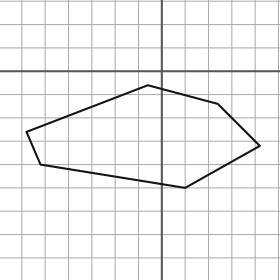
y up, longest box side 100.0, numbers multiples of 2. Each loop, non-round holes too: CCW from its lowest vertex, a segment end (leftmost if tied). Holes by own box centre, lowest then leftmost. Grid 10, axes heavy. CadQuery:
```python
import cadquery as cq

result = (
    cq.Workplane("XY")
    .moveTo(10.0, -50.0)
    .lineTo(42.0, -32.0)
    .lineTo(24.0, -14.0)
    .lineTo(-6.0, -6.0)
    .lineTo(-58.0, -26.0)
    .lineTo(-52.0, -40.0)
    .close()
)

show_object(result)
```